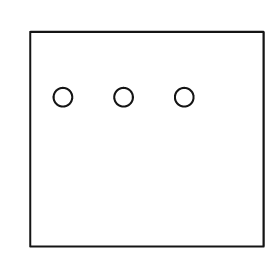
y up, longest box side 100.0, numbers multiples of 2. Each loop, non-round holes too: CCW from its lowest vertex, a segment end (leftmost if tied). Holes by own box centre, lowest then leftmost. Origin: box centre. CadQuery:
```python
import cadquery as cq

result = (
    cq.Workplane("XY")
    .moveTo(-50.0, -46.0)
    .lineTo(50.0, -46.0)
    .lineTo(50.0, 46.0)
    .lineTo(-50.0, 46.0)
    .close()
    .moveTo(-36.0, 18.0)
    .circle(4.0)
    .moveTo(-10.0, 18.0)
    .circle(4.0)
    .moveTo(16.0, 18.0)
    .circle(4.0)
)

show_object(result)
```